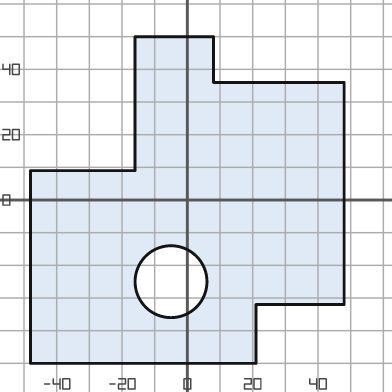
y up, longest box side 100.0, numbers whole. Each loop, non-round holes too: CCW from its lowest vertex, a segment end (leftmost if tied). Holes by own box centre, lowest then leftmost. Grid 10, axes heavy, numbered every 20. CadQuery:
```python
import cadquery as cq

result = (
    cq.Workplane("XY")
    .moveTo(-48.0, -50.0)
    .lineTo(21.0, -50.0)
    .lineTo(21.0, -32.0)
    .lineTo(48.0, -32.0)
    .lineTo(48.0, 36.0)
    .lineTo(8.0, 36.0)
    .lineTo(8.0, 50.0)
    .lineTo(-16.0, 50.0)
    .lineTo(-16.0, 9.0)
    .lineTo(-48.0, 9.0)
    .close()
    .moveTo(-5.0, -25.0)
    .circle(11.0)
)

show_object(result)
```